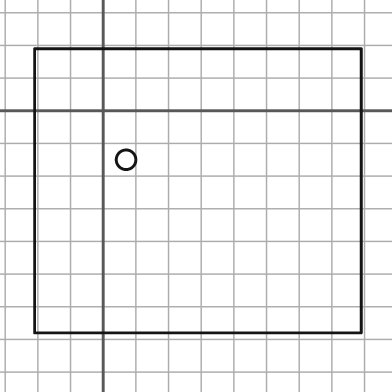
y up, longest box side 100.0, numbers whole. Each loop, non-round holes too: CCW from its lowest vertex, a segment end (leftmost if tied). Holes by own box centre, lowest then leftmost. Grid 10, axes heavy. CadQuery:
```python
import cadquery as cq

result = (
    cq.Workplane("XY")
    .moveTo(-21.0, -68.0)
    .lineTo(79.0, -68.0)
    .lineTo(79.0, 19.0)
    .lineTo(-21.0, 19.0)
    .close()
    .moveTo(7.0, -15.0)
    .circle(3.0)
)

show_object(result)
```